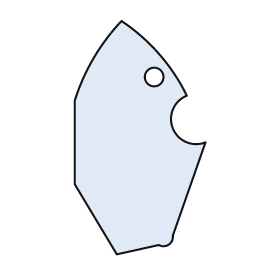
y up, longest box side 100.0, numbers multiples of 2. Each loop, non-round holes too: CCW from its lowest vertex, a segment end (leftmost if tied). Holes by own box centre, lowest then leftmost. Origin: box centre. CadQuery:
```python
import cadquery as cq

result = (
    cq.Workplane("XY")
    .moveTo(-10.0, -50.0)
    .lineTo(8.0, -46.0)
    .threePointArc((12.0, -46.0), (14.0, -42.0))
    .lineTo(28.0, -2.0)
    .threePointArc((14.0, 4.0), (20.0, 18.0))
    .threePointArc((8.0, 36.0), (-8.0, 50.0))
    .threePointArc((-20.0, 34.0), (-28.0, 16.0))
    .lineTo(-28.0, -20.0)
    .close()
    .moveTo(6.0, 26.0)
    .circle(4.0)
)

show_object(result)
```